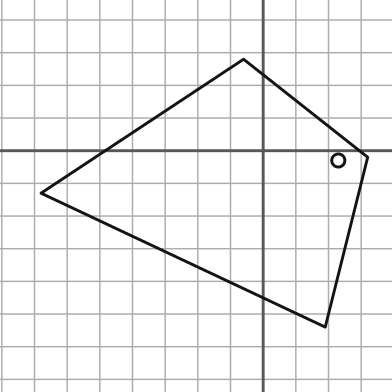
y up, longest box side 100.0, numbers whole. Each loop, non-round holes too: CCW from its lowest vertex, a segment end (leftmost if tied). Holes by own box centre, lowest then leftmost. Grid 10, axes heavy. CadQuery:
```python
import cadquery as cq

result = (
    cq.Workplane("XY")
    .moveTo(19.0, -54.0)
    .lineTo(32.0, -2.0)
    .lineTo(-6.0, 28.0)
    .lineTo(-68.0, -13.0)
    .close()
    .moveTo(23.0, -3.0)
    .circle(2.0)
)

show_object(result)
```